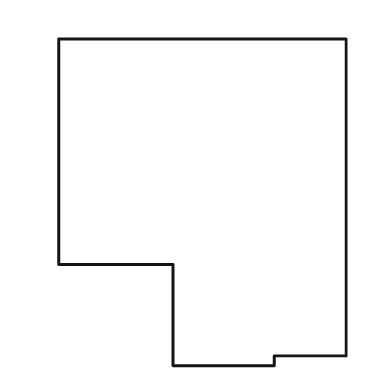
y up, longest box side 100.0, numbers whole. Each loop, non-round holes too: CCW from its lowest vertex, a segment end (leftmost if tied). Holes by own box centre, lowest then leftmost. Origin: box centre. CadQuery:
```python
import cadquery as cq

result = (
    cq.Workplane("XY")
    .moveTo(-9.0, -50.0)
    .lineTo(22.0, -50.0)
    .lineTo(22.0, -47.0)
    .lineTo(44.0, -47.0)
    .lineTo(44.0, 50.0)
    .lineTo(-44.0, 50.0)
    .lineTo(-44.0, -19.0)
    .lineTo(-9.0, -19.0)
    .close()
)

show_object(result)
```